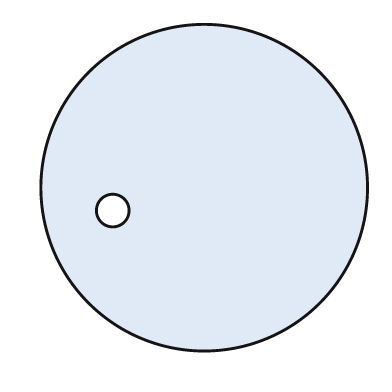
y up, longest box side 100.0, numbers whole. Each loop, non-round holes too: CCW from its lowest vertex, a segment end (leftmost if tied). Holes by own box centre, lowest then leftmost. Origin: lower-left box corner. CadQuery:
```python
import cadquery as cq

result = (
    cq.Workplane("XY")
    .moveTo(50.0, 50.0)
    .circle(50.0)
    .moveTo(22.0, 43.0)
    .circle(5.0)
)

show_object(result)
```